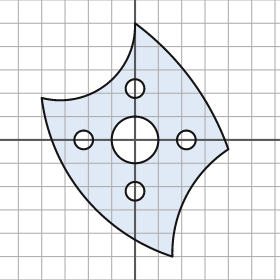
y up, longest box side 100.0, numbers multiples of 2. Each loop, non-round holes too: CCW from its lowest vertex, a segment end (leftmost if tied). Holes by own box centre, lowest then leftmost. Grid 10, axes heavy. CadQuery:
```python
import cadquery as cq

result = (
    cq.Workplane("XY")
    .moveTo(16.0, -50.0)
    .threePointArc((22.0, -24.0), (40.0, -4.0))
    .threePointArc((24.0, 26.0), (0.0, 50.0))
    .threePointArc((-12.0, 24.0), (-40.0, 18.0))
    .threePointArc((-22.0, -24.0), (16.0, -50.0))
    .close()
    .moveTo(0.0, -22.0)
    .circle(4.0)
    .moveTo(-22.0, 0.0)
    .circle(4.0)
    .moveTo(0.0, 0.0)
    .circle(10.0)
    .moveTo(22.0, 0.0)
    .circle(4.0)
    .moveTo(0.0, 22.0)
    .circle(4.0)
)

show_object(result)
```